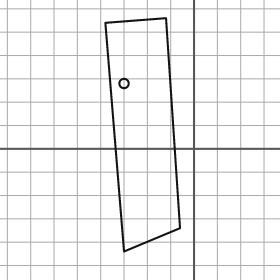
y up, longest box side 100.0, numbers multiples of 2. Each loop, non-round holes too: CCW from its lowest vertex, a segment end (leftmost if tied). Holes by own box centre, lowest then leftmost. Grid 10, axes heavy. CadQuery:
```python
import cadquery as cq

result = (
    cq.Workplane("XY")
    .moveTo(-30.0, -44.0)
    .lineTo(-6.0, -34.0)
    .lineTo(-12.0, 56.0)
    .lineTo(-38.0, 54.0)
    .close()
    .moveTo(-30.0, 28.0)
    .circle(2.0)
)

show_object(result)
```